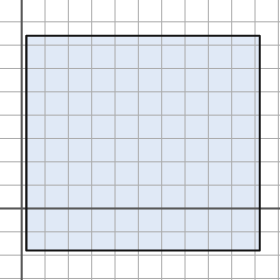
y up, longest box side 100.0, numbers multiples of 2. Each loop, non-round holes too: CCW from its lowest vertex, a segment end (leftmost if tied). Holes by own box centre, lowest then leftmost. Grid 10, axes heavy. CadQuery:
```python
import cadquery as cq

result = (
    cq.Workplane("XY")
    .moveTo(2.0, -18.0)
    .lineTo(102.0, -18.0)
    .lineTo(102.0, 74.0)
    .lineTo(2.0, 74.0)
    .close()
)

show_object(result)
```